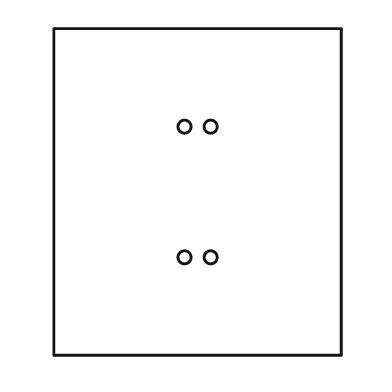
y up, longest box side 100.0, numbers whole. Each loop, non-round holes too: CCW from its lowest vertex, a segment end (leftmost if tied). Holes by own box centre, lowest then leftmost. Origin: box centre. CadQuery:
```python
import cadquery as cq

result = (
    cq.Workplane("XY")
    .moveTo(-44.0, -50.0)
    .lineTo(44.0, -50.0)
    .lineTo(44.0, 50.0)
    .lineTo(-44.0, 50.0)
    .close()
    .moveTo(-4.0, -20.0)
    .circle(2.0)
    .moveTo(4.0, -20.0)
    .circle(2.0)
    .moveTo(-4.0, 20.0)
    .circle(2.0)
    .moveTo(4.0, 20.0)
    .circle(2.0)
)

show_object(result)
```